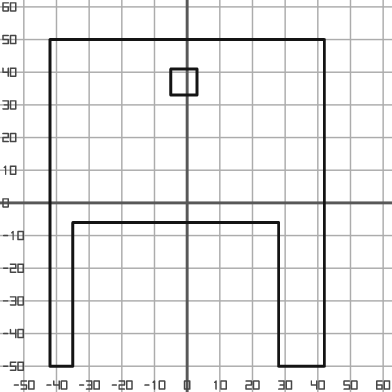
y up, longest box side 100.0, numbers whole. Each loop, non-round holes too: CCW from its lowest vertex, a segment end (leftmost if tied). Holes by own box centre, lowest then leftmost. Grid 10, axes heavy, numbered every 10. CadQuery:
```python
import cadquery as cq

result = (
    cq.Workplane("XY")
    .moveTo(-42.0, -50.0)
    .lineTo(-35.0, -50.0)
    .lineTo(-35.0, -6.0)
    .lineTo(28.0, -6.0)
    .lineTo(28.0, -50.0)
    .lineTo(42.0, -50.0)
    .lineTo(42.0, 50.0)
    .lineTo(-42.0, 50.0)
    .close()
    .moveTo(-5.0, 33.0)
    .lineTo(3.0, 33.0)
    .lineTo(3.0, 41.0)
    .lineTo(-5.0, 41.0)
    .close()
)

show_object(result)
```